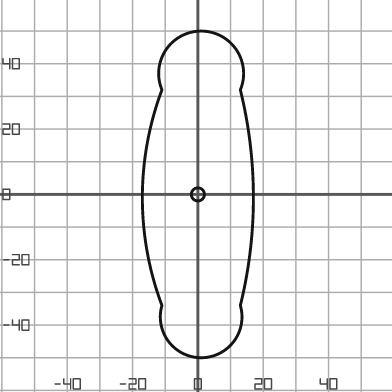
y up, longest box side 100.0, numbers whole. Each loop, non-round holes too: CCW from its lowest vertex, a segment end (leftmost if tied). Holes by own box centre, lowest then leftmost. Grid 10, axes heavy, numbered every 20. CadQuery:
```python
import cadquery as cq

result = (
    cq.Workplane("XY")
    .moveTo(-11.0, -34.0)
    .threePointArc((1.0, -50.0), (13.0, -34.0))
    .threePointArc((17.0, -1.0), (13.0, 32.0))
    .threePointArc((1.0, 50.0), (-11.0, 32.0))
    .threePointArc((-17.0, -1.0), (-11.0, -34.0))
    .close()
    .moveTo(0.0, 0.0)
    .circle(2.0)
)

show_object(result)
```